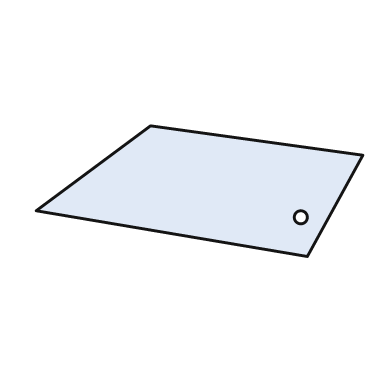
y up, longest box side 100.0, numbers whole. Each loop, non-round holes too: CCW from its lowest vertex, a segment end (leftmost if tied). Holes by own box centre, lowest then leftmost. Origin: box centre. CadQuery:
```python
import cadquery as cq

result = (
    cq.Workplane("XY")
    .moveTo(33.0, -20.0)
    .lineTo(50.0, 11.0)
    .lineTo(-15.0, 20.0)
    .lineTo(-50.0, -6.0)
    .close()
    .moveTo(31.0, -8.0)
    .circle(2.0)
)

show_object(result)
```